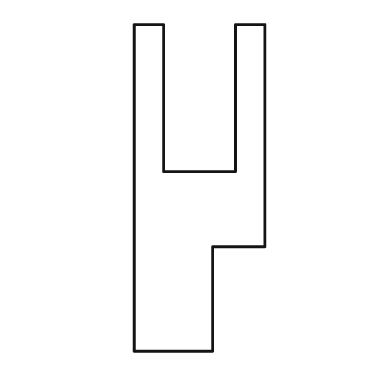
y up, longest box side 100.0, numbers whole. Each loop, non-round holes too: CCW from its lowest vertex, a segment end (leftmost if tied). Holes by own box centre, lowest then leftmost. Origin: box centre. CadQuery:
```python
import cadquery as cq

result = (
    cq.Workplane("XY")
    .moveTo(-20.0, -50.0)
    .lineTo(4.0, -50.0)
    .lineTo(4.0, -18.0)
    .lineTo(20.0, -18.0)
    .lineTo(20.0, 50.0)
    .lineTo(11.0, 50.0)
    .lineTo(11.0, 5.0)
    .lineTo(-11.0, 5.0)
    .lineTo(-11.0, 50.0)
    .lineTo(-20.0, 50.0)
    .close()
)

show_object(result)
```